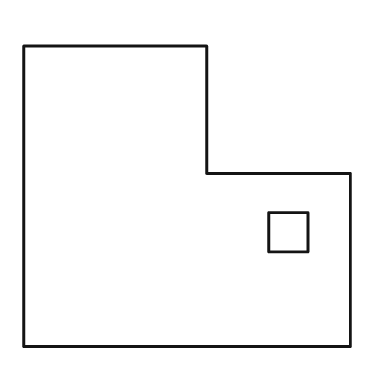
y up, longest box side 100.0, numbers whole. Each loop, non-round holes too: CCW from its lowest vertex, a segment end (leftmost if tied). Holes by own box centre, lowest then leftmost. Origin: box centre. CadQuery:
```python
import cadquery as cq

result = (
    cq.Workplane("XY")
    .moveTo(-50.0, -46.0)
    .lineTo(50.0, -46.0)
    .lineTo(50.0, 7.0)
    .lineTo(6.0, 7.0)
    .lineTo(6.0, 46.0)
    .lineTo(-50.0, 46.0)
    .close()
    .moveTo(25.0, -17.0)
    .lineTo(37.0, -17.0)
    .lineTo(37.0, -5.0)
    .lineTo(25.0, -5.0)
    .close()
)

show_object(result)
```